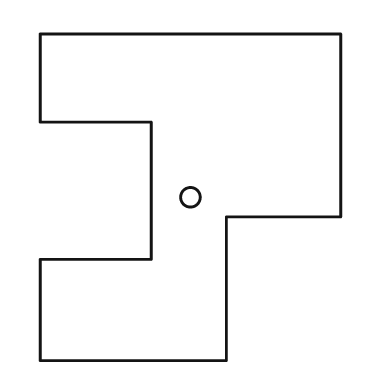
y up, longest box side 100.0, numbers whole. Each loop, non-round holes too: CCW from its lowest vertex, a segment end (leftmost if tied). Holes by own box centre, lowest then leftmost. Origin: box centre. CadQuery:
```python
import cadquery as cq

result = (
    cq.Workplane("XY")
    .moveTo(-46.0, -50.0)
    .lineTo(11.0, -50.0)
    .lineTo(11.0, -6.0)
    .lineTo(46.0, -6.0)
    .lineTo(46.0, 50.0)
    .lineTo(-46.0, 50.0)
    .lineTo(-46.0, 23.0)
    .lineTo(-12.0, 23.0)
    .lineTo(-12.0, -19.0)
    .lineTo(-46.0, -19.0)
    .close()
    .moveTo(0.0, 0.0)
    .circle(3.0)
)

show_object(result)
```